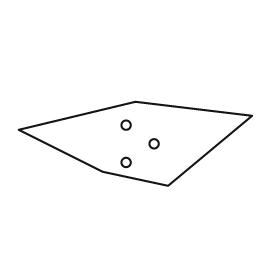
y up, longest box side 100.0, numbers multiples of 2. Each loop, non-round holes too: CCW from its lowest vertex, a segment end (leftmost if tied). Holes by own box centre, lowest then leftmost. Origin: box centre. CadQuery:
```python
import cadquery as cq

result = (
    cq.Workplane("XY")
    .moveTo(14.0, -18.0)
    .lineTo(50.0, 12.0)
    .lineTo(0.0, 18.0)
    .lineTo(-50.0, 6.0)
    .lineTo(-14.0, -12.0)
    .close()
    .moveTo(-4.0, -8.0)
    .circle(2.0)
    .moveTo(8.0, 0.0)
    .circle(2.0)
    .moveTo(-4.0, 8.0)
    .circle(2.0)
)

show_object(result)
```